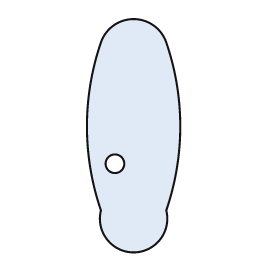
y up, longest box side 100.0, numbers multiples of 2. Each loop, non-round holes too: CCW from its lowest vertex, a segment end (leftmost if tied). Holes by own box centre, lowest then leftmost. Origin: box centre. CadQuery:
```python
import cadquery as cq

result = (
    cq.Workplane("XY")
    .moveTo(-14.0, -32.0)
    .threePointArc((0.0, -50.0), (14.0, -32.0))
    .threePointArc((20.0, 4.0), (14.0, 40.0))
    .threePointArc((0.0, 50.0), (-14.0, 40.0))
    .threePointArc((-20.0, 4.0), (-14.0, -32.0))
    .close()
    .moveTo(-8.0, -12.0)
    .circle(4.0)
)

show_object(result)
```